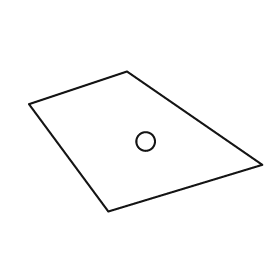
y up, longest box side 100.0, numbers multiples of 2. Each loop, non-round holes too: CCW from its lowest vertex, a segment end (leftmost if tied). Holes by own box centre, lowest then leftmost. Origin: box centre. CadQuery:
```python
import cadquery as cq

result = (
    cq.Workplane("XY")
    .moveTo(-16.0, -30.0)
    .lineTo(50.0, -10.0)
    .lineTo(-8.0, 30.0)
    .lineTo(-50.0, 16.0)
    .close()
    .moveTo(0.0, 0.0)
    .circle(4.0)
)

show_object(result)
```